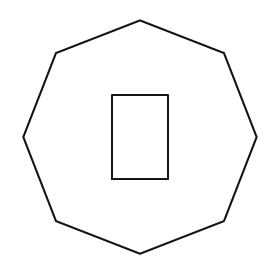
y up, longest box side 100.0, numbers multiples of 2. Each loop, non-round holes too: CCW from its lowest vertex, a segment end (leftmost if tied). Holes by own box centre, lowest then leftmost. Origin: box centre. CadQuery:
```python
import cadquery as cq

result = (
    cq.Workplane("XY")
    .moveTo(0.0, -50.0)
    .lineTo(36.0, -36.0)
    .lineTo(50.0, 0.0)
    .lineTo(36.0, 36.0)
    .lineTo(0.0, 50.0)
    .lineTo(-36.0, 36.0)
    .lineTo(-50.0, 0.0)
    .lineTo(-36.0, -36.0)
    .close()
    .moveTo(-12.0, -18.0)
    .lineTo(12.0, -18.0)
    .lineTo(12.0, 18.0)
    .lineTo(-12.0, 18.0)
    .close()
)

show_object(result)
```